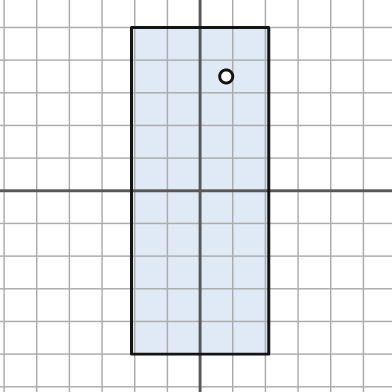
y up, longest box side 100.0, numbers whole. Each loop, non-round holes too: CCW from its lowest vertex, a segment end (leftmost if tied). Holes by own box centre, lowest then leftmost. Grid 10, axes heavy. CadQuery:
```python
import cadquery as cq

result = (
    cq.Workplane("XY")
    .moveTo(-21.0, -50.0)
    .lineTo(21.0, -50.0)
    .lineTo(21.0, 50.0)
    .lineTo(-21.0, 50.0)
    .close()
    .moveTo(8.0, 35.0)
    .circle(2.0)
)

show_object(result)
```